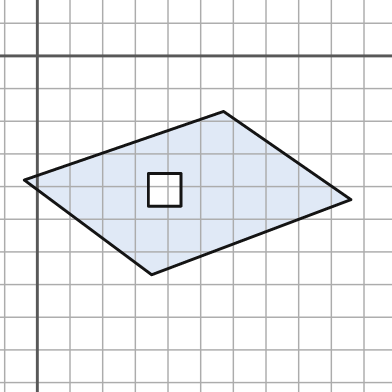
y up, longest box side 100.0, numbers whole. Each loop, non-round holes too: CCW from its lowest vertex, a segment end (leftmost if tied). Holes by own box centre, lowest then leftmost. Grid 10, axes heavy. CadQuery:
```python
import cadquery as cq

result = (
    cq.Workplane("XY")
    .moveTo(35.0, -67.0)
    .lineTo(96.0, -44.0)
    .lineTo(57.0, -17.0)
    .lineTo(-4.0, -38.0)
    .close()
    .moveTo(34.0, -46.0)
    .lineTo(44.0, -46.0)
    .lineTo(44.0, -36.0)
    .lineTo(34.0, -36.0)
    .close()
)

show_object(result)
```